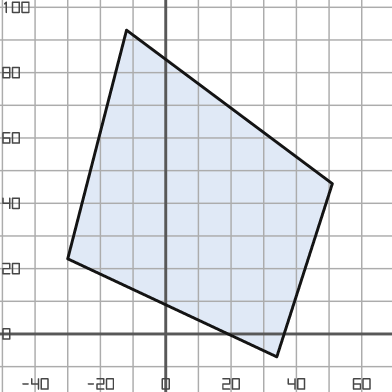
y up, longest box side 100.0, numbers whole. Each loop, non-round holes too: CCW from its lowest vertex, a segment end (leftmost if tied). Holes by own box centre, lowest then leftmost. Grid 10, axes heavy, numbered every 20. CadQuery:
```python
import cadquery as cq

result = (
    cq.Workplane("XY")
    .moveTo(34.0, -7.0)
    .lineTo(51.0, 46.0)
    .lineTo(-12.0, 93.0)
    .lineTo(-30.0, 23.0)
    .close()
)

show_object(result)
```